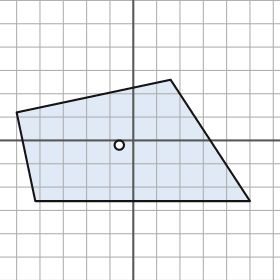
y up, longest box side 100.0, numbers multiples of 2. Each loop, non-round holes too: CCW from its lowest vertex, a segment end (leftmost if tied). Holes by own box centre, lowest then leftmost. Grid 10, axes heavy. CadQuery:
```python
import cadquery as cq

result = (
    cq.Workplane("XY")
    .moveTo(-42.0, -26.0)
    .lineTo(50.0, -26.0)
    .lineTo(16.0, 26.0)
    .lineTo(-50.0, 12.0)
    .close()
    .moveTo(-6.0, -2.0)
    .circle(2.0)
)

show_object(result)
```